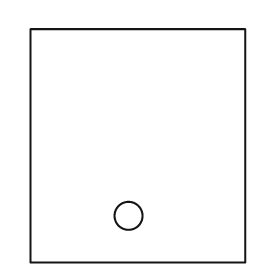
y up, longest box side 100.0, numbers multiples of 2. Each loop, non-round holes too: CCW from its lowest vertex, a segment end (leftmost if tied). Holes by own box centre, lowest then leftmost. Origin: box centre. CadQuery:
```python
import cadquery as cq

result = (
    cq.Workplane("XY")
    .moveTo(-46.0, -50.0)
    .lineTo(46.0, -50.0)
    .lineTo(46.0, 50.0)
    .lineTo(-46.0, 50.0)
    .close()
    .moveTo(-4.0, -30.0)
    .circle(6.0)
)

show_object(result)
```